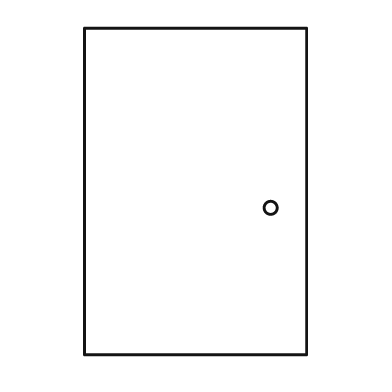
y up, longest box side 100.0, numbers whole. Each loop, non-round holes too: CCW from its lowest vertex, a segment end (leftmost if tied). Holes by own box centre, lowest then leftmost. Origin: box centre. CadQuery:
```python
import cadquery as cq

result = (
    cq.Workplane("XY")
    .moveTo(-34.0, -50.0)
    .lineTo(34.0, -50.0)
    .lineTo(34.0, 50.0)
    .lineTo(-34.0, 50.0)
    .close()
    .moveTo(23.0, -5.0)
    .circle(2.0)
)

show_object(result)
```